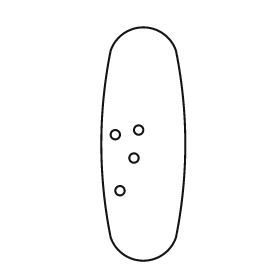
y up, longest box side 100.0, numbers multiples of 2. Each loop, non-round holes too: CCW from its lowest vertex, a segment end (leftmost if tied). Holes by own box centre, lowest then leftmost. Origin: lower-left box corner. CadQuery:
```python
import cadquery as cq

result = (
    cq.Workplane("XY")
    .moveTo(4.0, 10.0)
    .threePointArc((18.0, 0.0), (32.0, 10.0))
    .threePointArc((36.0, 50.0), (32.0, 90.0))
    .threePointArc((18.0, 100.0), (4.0, 90.0))
    .threePointArc((0.0, 50.0), (4.0, 10.0))
    .close()
    .moveTo(8.0, 30.0)
    .circle(2.0)
    .moveTo(14.0, 44.0)
    .circle(2.0)
    .moveTo(6.0, 54.0)
    .circle(2.0)
    .moveTo(16.0, 56.0)
    .circle(2.0)
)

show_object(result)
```